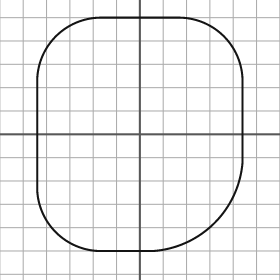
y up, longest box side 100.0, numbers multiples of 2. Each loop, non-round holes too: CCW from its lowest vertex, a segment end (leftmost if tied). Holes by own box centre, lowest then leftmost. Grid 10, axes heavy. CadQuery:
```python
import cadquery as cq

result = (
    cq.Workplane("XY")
    .moveTo(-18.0, -50.0)
    .lineTo(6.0, -50.0)
    .threePointArc((32.0, -38.0), (44.0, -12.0))
    .lineTo(44.0, 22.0)
    .threePointArc((36.0, 42.0), (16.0, 50.0))
    .lineTo(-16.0, 50.0)
    .threePointArc((-36.0, 42.0), (-44.0, 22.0))
    .lineTo(-44.0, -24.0)
    .threePointArc((-36.0, -42.0), (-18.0, -50.0))
    .close()
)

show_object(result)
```